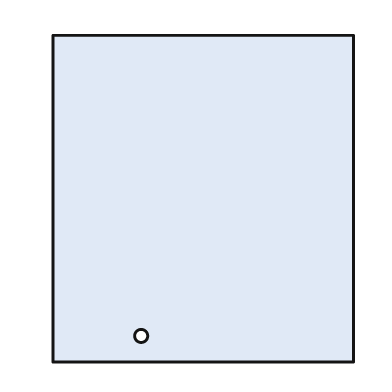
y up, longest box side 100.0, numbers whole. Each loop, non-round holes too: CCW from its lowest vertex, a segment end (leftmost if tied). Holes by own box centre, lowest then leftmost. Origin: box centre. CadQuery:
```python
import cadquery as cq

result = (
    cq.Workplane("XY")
    .moveTo(-46.0, -50.0)
    .lineTo(46.0, -50.0)
    .lineTo(46.0, 50.0)
    .lineTo(-46.0, 50.0)
    .close()
    .moveTo(-19.0, -42.0)
    .circle(2.0)
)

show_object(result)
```